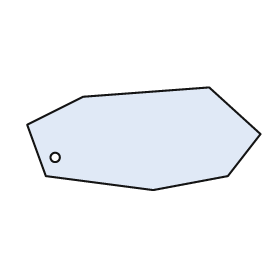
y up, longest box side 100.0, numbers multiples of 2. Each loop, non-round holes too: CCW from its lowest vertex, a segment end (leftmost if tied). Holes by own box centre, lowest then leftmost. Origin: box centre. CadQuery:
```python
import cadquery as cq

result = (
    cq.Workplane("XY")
    .moveTo(4.0, -22.0)
    .lineTo(36.0, -16.0)
    .lineTo(50.0, 2.0)
    .lineTo(28.0, 22.0)
    .lineTo(-26.0, 18.0)
    .lineTo(-50.0, 6.0)
    .lineTo(-42.0, -16.0)
    .close()
    .moveTo(-38.0, -8.0)
    .circle(2.0)
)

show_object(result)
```